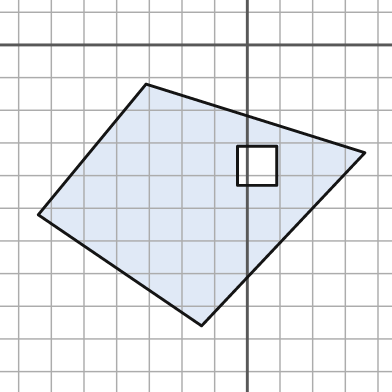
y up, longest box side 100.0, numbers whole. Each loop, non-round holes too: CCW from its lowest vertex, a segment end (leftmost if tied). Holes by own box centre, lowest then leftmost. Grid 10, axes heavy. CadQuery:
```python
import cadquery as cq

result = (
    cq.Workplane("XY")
    .moveTo(-14.0, -86.0)
    .lineTo(36.0, -33.0)
    .lineTo(-31.0, -12.0)
    .lineTo(-64.0, -52.0)
    .close()
    .moveTo(-3.0, -43.0)
    .lineTo(9.0, -43.0)
    .lineTo(9.0, -31.0)
    .lineTo(-3.0, -31.0)
    .close()
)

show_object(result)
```